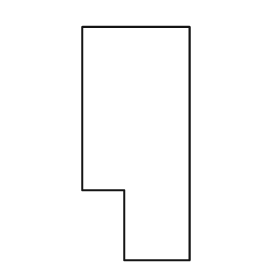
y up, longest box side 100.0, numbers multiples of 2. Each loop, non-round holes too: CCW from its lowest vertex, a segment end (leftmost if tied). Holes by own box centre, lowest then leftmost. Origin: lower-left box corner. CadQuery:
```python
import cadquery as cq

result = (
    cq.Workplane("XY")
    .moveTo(18.0, 0.0)
    .lineTo(46.0, 0.0)
    .lineTo(46.0, 100.0)
    .lineTo(0.0, 100.0)
    .lineTo(0.0, 30.0)
    .lineTo(18.0, 30.0)
    .close()
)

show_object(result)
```